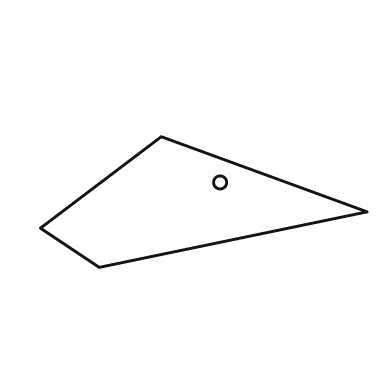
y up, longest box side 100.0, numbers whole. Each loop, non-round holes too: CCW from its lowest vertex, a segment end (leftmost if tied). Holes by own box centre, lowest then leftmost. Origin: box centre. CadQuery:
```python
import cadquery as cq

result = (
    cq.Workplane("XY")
    .moveTo(-32.0, -20.0)
    .lineTo(50.0, -3.0)
    .lineTo(-13.0, 20.0)
    .lineTo(-50.0, -8.0)
    .close()
    .moveTo(5.0, 6.0)
    .circle(2.0)
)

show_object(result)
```